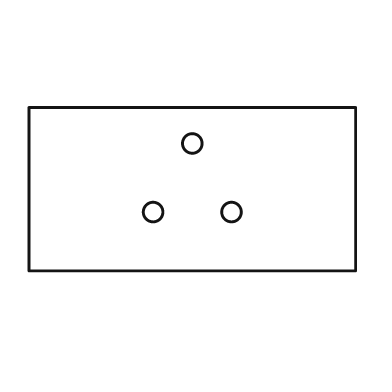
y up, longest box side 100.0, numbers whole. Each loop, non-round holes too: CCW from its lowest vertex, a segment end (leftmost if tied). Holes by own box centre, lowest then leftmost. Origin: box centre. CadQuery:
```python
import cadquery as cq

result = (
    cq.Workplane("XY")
    .moveTo(-50.0, -25.0)
    .lineTo(50.0, -25.0)
    .lineTo(50.0, 25.0)
    .lineTo(-50.0, 25.0)
    .close()
    .moveTo(-12.0, -7.0)
    .circle(3.0)
    .moveTo(12.0, -7.0)
    .circle(3.0)
    .moveTo(0.0, 14.0)
    .circle(3.0)
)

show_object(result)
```